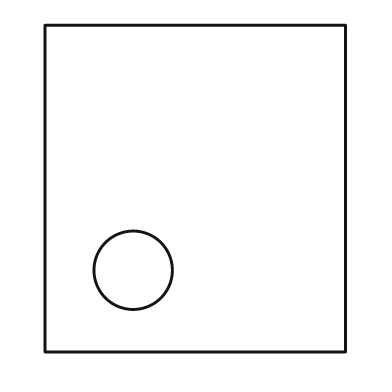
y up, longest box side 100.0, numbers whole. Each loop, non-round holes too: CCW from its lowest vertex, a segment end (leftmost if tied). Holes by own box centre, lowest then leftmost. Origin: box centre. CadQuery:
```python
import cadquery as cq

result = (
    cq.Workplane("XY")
    .moveTo(-46.0, -50.0)
    .lineTo(46.0, -50.0)
    .lineTo(46.0, 50.0)
    .lineTo(-46.0, 50.0)
    .close()
    .moveTo(-19.0, -25.0)
    .circle(12.0)
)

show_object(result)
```